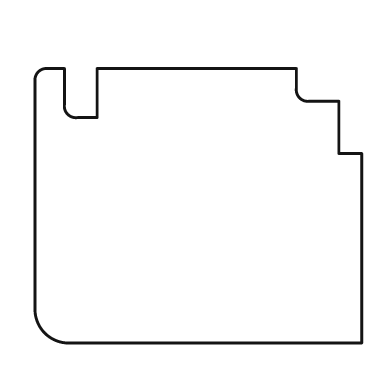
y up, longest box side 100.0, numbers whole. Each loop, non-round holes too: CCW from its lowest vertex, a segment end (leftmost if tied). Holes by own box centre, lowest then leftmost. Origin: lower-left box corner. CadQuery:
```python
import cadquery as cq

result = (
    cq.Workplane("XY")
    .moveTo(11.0, 0.0)
    .lineTo(100.0, 0.0)
    .lineTo(100.0, 58.0)
    .lineTo(93.0, 58.0)
    .lineTo(93.0, 74.0)
    .lineTo(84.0, 74.0)
    .threePointArc((81.0, 75.0), (80.0, 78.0))
    .lineTo(80.0, 84.0)
    .lineTo(19.0, 84.0)
    .lineTo(19.0, 69.0)
    .lineTo(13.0, 69.0)
    .threePointArc((10.0, 70.0), (9.0, 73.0))
    .lineTo(9.0, 84.0)
    .lineTo(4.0, 84.0)
    .threePointArc((1.0, 83.0), (0.0, 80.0))
    .lineTo(0.0, 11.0)
    .threePointArc((3.0, 3.0), (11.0, 0.0))
    .close()
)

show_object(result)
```